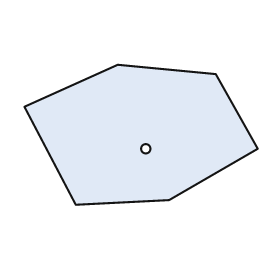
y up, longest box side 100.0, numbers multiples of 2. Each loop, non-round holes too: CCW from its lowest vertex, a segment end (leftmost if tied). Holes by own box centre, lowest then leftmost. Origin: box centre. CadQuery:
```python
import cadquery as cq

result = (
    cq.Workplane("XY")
    .moveTo(-28.0, -30.0)
    .lineTo(12.0, -28.0)
    .lineTo(50.0, -6.0)
    .lineTo(32.0, 26.0)
    .lineTo(-10.0, 30.0)
    .lineTo(-50.0, 12.0)
    .close()
    .moveTo(2.0, -6.0)
    .circle(2.0)
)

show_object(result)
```